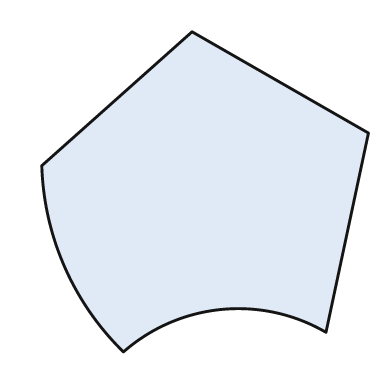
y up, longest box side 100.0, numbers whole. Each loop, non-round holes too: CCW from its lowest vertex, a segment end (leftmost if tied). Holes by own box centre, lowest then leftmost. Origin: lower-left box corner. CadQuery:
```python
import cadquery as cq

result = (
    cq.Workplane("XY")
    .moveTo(25.0, 0.0)
    .threePointArc((55.0, 13.0), (87.0, 6.0))
    .lineTo(100.0, 67.0)
    .lineTo(46.0, 98.0)
    .lineTo(0.0, 57.0)
    .threePointArc((7.0, 26.0), (25.0, 0.0))
    .close()
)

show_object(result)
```